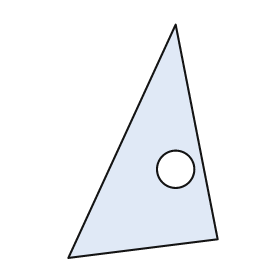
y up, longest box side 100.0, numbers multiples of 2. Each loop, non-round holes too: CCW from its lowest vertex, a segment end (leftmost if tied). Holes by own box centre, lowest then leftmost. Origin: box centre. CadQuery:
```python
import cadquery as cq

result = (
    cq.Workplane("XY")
    .moveTo(-32.0, -50.0)
    .lineTo(32.0, -42.0)
    .lineTo(14.0, 50.0)
    .close()
    .moveTo(14.0, -12.0)
    .circle(8.0)
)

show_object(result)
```